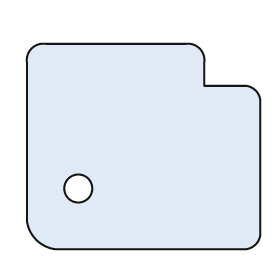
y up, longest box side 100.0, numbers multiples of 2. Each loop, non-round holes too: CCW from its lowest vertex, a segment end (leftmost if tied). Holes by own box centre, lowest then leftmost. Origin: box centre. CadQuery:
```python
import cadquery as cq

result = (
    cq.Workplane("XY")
    .moveTo(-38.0, -44.0)
    .lineTo(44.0, -44.0)
    .threePointArc((48.0, -42.0), (50.0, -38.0))
    .lineTo(50.0, 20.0)
    .threePointArc((48.0, 24.0), (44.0, 26.0))
    .lineTo(26.0, 26.0)
    .lineTo(26.0, 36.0)
    .threePointArc((24.0, 42.0), (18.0, 44.0))
    .lineTo(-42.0, 44.0)
    .threePointArc((-48.0, 42.0), (-50.0, 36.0))
    .lineTo(-50.0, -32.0)
    .threePointArc((-46.0, -40.0), (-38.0, -44.0))
    .close()
    .moveTo(-28.0, -18.0)
    .circle(6.0)
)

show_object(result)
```